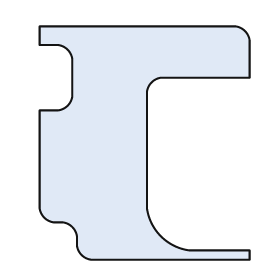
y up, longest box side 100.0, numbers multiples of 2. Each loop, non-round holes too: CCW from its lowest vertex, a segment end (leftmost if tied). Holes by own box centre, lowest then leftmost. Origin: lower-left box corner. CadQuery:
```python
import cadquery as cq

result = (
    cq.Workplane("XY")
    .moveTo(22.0, 0.0)
    .lineTo(90.0, 0.0)
    .lineTo(90.0, 4.0)
    .lineTo(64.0, 4.0)
    .threePointArc((52.0, 10.0), (46.0, 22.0))
    .lineTo(46.0, 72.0)
    .threePointArc((48.0, 76.0), (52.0, 78.0))
    .lineTo(90.0, 78.0)
    .lineTo(90.0, 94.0)
    .threePointArc((88.0, 98.0), (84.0, 100.0))
    .lineTo(0.0, 100.0)
    .lineTo(0.0, 92.0)
    .lineTo(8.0, 92.0)
    .threePointArc((12.0, 90.0), (14.0, 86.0))
    .lineTo(14.0, 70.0)
    .threePointArc((12.0, 66.0), (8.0, 64.0))
    .lineTo(0.0, 64.0)
    .lineTo(0.0, 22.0)
    .threePointArc((2.0, 18.0), (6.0, 16.0))
    .lineTo(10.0, 16.0)
    .threePointArc((14.0, 14.0), (16.0, 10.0))
    .lineTo(16.0, 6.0)
    .threePointArc((18.0, 2.0), (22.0, 0.0))
    .close()
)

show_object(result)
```